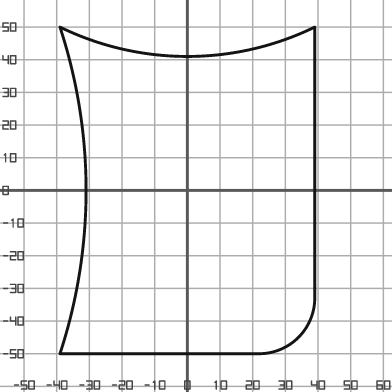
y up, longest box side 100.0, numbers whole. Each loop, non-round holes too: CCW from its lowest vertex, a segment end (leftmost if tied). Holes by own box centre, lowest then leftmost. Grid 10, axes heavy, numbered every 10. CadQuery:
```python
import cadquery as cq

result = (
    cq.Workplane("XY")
    .moveTo(-39.0, -50.0)
    .lineTo(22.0, -50.0)
    .threePointArc((34.0, -45.0), (39.0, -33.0))
    .lineTo(39.0, 50.0)
    .threePointArc((0.0, 41.0), (-39.0, 50.0))
    .threePointArc((-31.0, 0.0), (-39.0, -50.0))
    .close()
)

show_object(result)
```